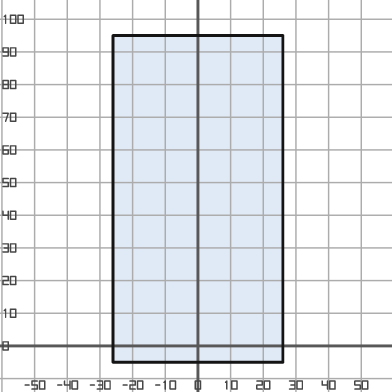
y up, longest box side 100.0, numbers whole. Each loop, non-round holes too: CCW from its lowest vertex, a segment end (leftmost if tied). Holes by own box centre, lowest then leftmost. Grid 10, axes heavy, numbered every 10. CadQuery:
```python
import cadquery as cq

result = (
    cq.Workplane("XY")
    .moveTo(-26.0, -5.0)
    .lineTo(26.0, -5.0)
    .lineTo(26.0, 95.0)
    .lineTo(-26.0, 95.0)
    .close()
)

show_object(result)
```